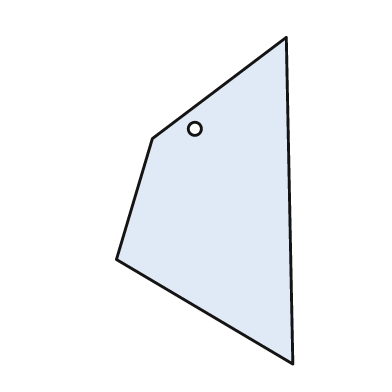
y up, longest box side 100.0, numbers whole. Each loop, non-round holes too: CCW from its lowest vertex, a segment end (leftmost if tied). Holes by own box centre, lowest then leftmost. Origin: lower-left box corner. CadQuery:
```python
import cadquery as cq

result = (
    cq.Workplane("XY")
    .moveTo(54.0, 0.0)
    .lineTo(52.0, 100.0)
    .lineTo(11.0, 69.0)
    .lineTo(0.0, 32.0)
    .close()
    .moveTo(24.0, 72.0)
    .circle(2.0)
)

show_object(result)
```